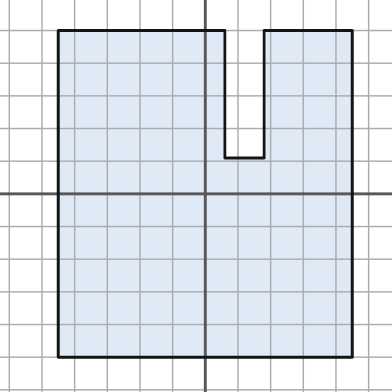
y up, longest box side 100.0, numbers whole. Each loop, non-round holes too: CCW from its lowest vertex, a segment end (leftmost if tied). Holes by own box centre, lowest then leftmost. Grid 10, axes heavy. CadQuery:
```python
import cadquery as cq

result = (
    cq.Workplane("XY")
    .moveTo(-45.0, -50.0)
    .lineTo(45.0, -50.0)
    .lineTo(45.0, 50.0)
    .lineTo(18.0, 50.0)
    .lineTo(18.0, 11.0)
    .lineTo(6.0, 11.0)
    .lineTo(6.0, 50.0)
    .lineTo(-45.0, 50.0)
    .close()
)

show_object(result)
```